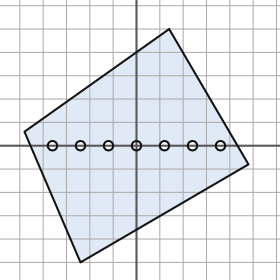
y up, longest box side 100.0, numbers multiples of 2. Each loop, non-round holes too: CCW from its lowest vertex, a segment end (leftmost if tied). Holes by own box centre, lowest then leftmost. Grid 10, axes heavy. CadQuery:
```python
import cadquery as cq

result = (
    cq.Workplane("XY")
    .moveTo(-24.0, -50.0)
    .lineTo(48.0, -8.0)
    .lineTo(14.0, 50.0)
    .lineTo(-48.0, 6.0)
    .close()
    .moveTo(-36.0, 0.0)
    .circle(2.0)
    .moveTo(-24.0, 0.0)
    .circle(2.0)
    .moveTo(-12.0, 0.0)
    .circle(2.0)
    .moveTo(0.0, 0.0)
    .circle(2.0)
    .moveTo(12.0, 0.0)
    .circle(2.0)
    .moveTo(24.0, 0.0)
    .circle(2.0)
    .moveTo(36.0, 0.0)
    .circle(2.0)
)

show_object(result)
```